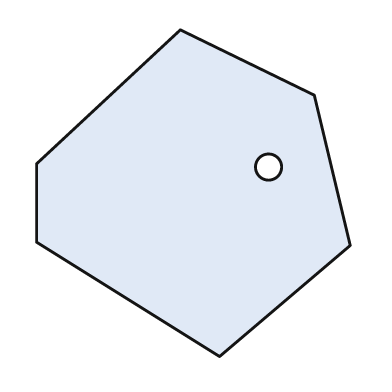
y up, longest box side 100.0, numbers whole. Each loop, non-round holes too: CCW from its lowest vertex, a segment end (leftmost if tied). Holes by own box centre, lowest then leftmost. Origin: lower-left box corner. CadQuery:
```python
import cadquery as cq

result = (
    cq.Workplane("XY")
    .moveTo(56.0, 0.0)
    .lineTo(96.0, 34.0)
    .lineTo(85.0, 80.0)
    .lineTo(44.0, 100.0)
    .lineTo(0.0, 59.0)
    .lineTo(0.0, 35.0)
    .close()
    .moveTo(71.0, 58.0)
    .circle(4.0)
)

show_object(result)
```